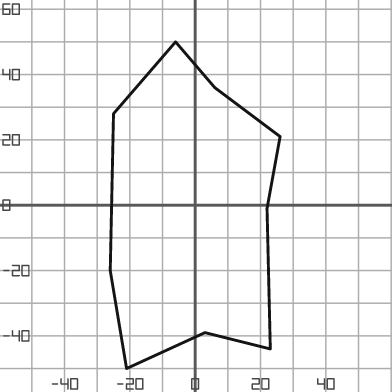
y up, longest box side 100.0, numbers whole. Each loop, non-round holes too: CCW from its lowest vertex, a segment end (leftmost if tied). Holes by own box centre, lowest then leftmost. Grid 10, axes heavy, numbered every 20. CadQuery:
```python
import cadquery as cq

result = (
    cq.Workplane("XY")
    .moveTo(-21.0, -50.0)
    .lineTo(3.0, -39.0)
    .lineTo(23.0, -44.0)
    .lineTo(22.0, -1.0)
    .lineTo(26.0, 21.0)
    .lineTo(6.0, 36.0)
    .lineTo(-6.0, 50.0)
    .lineTo(-25.0, 28.0)
    .lineTo(-26.0, -20.0)
    .close()
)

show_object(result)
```